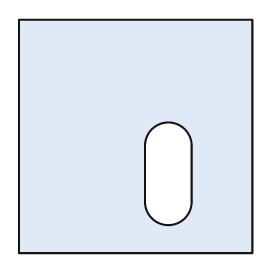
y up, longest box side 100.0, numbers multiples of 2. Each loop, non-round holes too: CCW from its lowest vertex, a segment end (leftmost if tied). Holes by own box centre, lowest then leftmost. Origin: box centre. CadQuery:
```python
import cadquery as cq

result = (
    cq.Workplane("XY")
    .moveTo(-50.0, -50.0)
    .lineTo(50.0, -50.0)
    .lineTo(50.0, 50.0)
    .lineTo(-50.0, 50.0)
    .close()
    .moveTo(4.0, -28.0)
    .threePointArc((14.0, -38.0), (24.0, -28.0))
    .lineTo(24.0, -4.0)
    .threePointArc((14.0, 6.0), (4.0, -4.0))
    .close()
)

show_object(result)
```